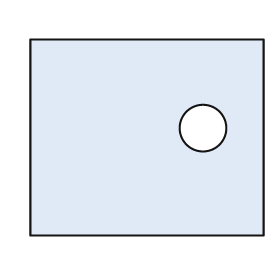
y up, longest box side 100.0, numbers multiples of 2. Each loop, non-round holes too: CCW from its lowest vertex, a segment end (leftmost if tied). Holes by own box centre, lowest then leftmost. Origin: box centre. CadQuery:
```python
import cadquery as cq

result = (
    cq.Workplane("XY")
    .moveTo(-50.0, -42.0)
    .lineTo(50.0, -42.0)
    .lineTo(50.0, 42.0)
    .lineTo(-50.0, 42.0)
    .close()
    .moveTo(24.0, 4.0)
    .circle(10.0)
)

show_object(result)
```